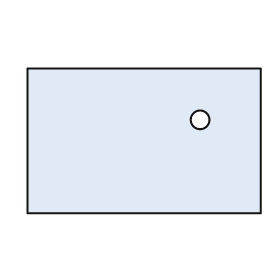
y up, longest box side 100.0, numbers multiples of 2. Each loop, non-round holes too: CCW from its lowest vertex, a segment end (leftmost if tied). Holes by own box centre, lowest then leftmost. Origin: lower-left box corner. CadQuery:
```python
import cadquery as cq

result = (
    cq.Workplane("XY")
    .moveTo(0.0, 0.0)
    .lineTo(100.0, 0.0)
    .lineTo(100.0, 62.0)
    .lineTo(0.0, 62.0)
    .close()
    .moveTo(74.0, 40.0)
    .circle(4.0)
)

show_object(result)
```